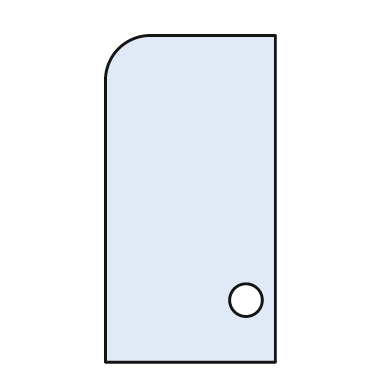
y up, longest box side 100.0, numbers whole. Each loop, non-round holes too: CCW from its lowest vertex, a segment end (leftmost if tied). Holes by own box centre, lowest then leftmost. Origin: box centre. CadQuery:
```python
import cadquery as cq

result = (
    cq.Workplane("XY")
    .moveTo(-26.0, -50.0)
    .lineTo(26.0, -50.0)
    .lineTo(26.0, 50.0)
    .lineTo(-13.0, 50.0)
    .threePointArc((-22.0, 46.0), (-26.0, 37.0))
    .close()
    .moveTo(17.0, -31.0)
    .circle(5.0)
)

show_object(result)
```